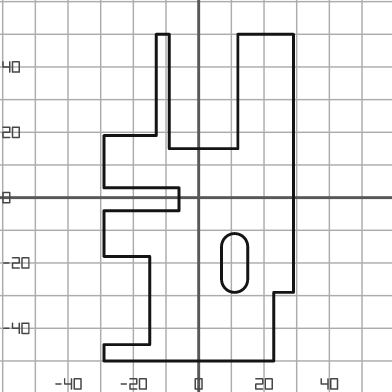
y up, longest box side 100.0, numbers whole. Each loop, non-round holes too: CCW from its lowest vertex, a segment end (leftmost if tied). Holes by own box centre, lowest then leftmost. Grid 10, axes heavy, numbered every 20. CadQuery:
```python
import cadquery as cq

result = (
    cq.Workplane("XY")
    .moveTo(-29.0, -50.0)
    .lineTo(23.0, -50.0)
    .lineTo(23.0, -29.0)
    .lineTo(29.0, -29.0)
    .lineTo(29.0, 50.0)
    .lineTo(12.0, 50.0)
    .lineTo(12.0, 15.0)
    .lineTo(-9.0, 15.0)
    .lineTo(-9.0, 50.0)
    .lineTo(-13.0, 50.0)
    .lineTo(-13.0, 19.0)
    .lineTo(-29.0, 19.0)
    .lineTo(-29.0, 3.0)
    .lineTo(-6.0, 3.0)
    .lineTo(-6.0, -4.0)
    .lineTo(-29.0, -4.0)
    .lineTo(-29.0, -18.0)
    .lineTo(-15.0, -18.0)
    .lineTo(-15.0, -45.0)
    .lineTo(-29.0, -45.0)
    .close()
    .moveTo(7.0, -25.0)
    .threePointArc((11.0, -29.0), (15.0, -25.0))
    .lineTo(15.0, -15.0)
    .threePointArc((11.0, -11.0), (7.0, -15.0))
    .close()
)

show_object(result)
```